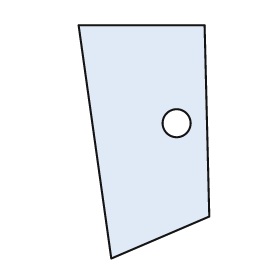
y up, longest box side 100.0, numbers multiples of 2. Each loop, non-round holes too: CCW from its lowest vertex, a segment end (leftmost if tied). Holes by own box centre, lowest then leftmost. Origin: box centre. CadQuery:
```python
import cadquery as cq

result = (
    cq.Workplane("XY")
    .moveTo(-14.0, -50.0)
    .lineTo(28.0, -32.0)
    .lineTo(26.0, 50.0)
    .lineTo(-28.0, 50.0)
    .close()
    .moveTo(14.0, 8.0)
    .circle(6.0)
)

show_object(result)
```